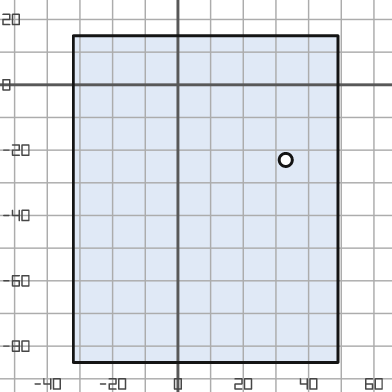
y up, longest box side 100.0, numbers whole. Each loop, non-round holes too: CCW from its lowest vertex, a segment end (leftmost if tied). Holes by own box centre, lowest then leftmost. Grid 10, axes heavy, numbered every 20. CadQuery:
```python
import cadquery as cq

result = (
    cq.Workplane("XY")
    .moveTo(-32.0, -85.0)
    .lineTo(49.0, -85.0)
    .lineTo(49.0, 15.0)
    .lineTo(-32.0, 15.0)
    .close()
    .moveTo(33.0, -23.0)
    .circle(2.0)
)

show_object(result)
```